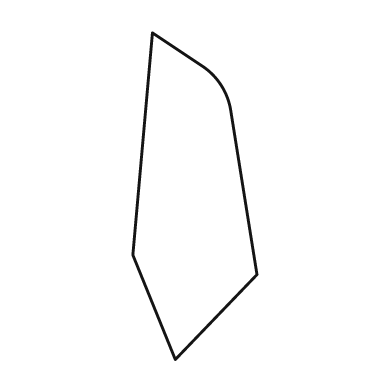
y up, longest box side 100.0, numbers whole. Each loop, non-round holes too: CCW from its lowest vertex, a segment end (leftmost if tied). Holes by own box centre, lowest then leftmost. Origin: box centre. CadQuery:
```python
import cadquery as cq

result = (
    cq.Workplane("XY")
    .moveTo(-6.0, -50.0)
    .lineTo(19.0, -24.0)
    .lineTo(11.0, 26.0)
    .threePointArc((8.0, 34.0), (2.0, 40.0))
    .lineTo(-13.0, 50.0)
    .lineTo(-19.0, -18.0)
    .close()
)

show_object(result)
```